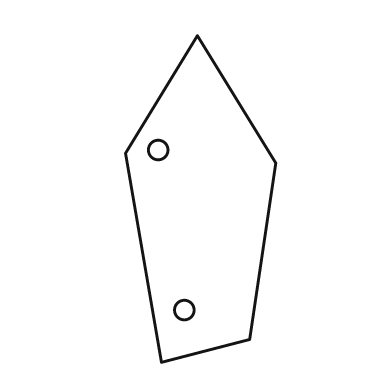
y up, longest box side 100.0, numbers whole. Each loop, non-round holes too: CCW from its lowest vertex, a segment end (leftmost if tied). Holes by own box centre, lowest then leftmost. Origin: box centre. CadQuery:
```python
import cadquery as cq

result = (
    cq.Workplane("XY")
    .moveTo(-12.0, -50.0)
    .lineTo(15.0, -43.0)
    .lineTo(23.0, 11.0)
    .lineTo(-1.0, 50.0)
    .lineTo(-23.0, 14.0)
    .close()
    .moveTo(-5.0, -34.0)
    .circle(3.0)
    .moveTo(-13.0, 15.0)
    .circle(3.0)
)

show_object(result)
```